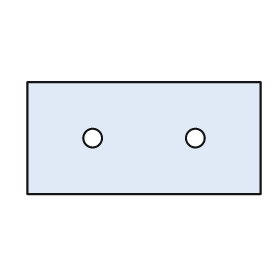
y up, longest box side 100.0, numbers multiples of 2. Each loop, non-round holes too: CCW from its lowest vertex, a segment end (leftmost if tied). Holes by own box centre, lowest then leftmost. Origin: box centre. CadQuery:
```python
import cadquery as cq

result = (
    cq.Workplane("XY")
    .moveTo(-50.0, -24.0)
    .lineTo(50.0, -24.0)
    .lineTo(50.0, 24.0)
    .lineTo(-50.0, 24.0)
    .close()
    .moveTo(-22.0, 0.0)
    .circle(4.0)
    .moveTo(22.0, 0.0)
    .circle(4.0)
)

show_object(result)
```